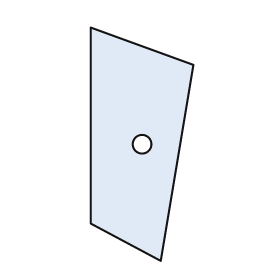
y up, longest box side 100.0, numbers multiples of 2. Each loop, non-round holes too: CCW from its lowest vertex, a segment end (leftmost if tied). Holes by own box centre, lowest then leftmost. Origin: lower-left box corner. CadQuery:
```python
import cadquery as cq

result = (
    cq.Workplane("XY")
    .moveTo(30.0, 0.0)
    .lineTo(44.0, 84.0)
    .lineTo(0.0, 100.0)
    .lineTo(0.0, 16.0)
    .close()
    .moveTo(22.0, 50.0)
    .circle(4.0)
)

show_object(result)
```